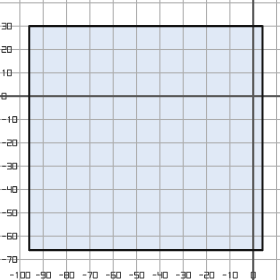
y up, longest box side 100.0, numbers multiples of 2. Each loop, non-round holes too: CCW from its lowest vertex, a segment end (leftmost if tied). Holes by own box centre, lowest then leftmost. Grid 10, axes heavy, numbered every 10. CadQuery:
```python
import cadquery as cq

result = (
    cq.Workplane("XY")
    .moveTo(-96.0, -66.0)
    .lineTo(4.0, -66.0)
    .lineTo(4.0, 30.0)
    .lineTo(-96.0, 30.0)
    .close()
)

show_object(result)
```